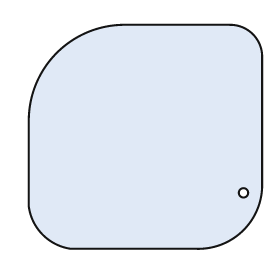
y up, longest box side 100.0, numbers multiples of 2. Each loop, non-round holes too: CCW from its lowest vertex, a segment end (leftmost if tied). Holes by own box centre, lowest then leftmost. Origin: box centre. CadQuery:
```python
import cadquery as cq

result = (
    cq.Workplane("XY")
    .moveTo(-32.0, -48.0)
    .lineTo(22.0, -48.0)
    .threePointArc((42.0, -40.0), (50.0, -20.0))
    .lineTo(50.0, 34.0)
    .threePointArc((46.0, 44.0), (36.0, 48.0))
    .lineTo(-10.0, 48.0)
    .threePointArc((-38.0, 36.0), (-50.0, 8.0))
    .lineTo(-50.0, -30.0)
    .threePointArc((-44.0, -42.0), (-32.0, -48.0))
    .close()
    .moveTo(42.0, -24.0)
    .circle(2.0)
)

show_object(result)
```